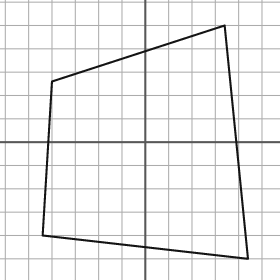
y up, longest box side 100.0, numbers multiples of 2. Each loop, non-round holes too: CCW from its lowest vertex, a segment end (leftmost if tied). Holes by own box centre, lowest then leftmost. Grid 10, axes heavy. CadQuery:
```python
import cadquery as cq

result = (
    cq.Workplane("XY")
    .moveTo(44.0, -50.0)
    .lineTo(34.0, 50.0)
    .lineTo(-40.0, 26.0)
    .lineTo(-44.0, -40.0)
    .close()
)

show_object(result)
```